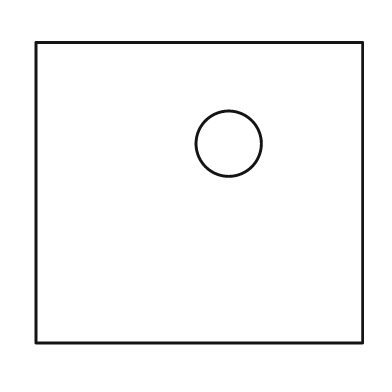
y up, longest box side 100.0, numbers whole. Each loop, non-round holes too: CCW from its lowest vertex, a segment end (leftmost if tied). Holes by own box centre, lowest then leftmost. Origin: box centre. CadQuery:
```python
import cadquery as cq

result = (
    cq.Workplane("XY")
    .moveTo(-50.0, -46.0)
    .lineTo(50.0, -46.0)
    .lineTo(50.0, 46.0)
    .lineTo(-50.0, 46.0)
    .close()
    .moveTo(9.0, 15.0)
    .circle(10.0)
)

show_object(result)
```